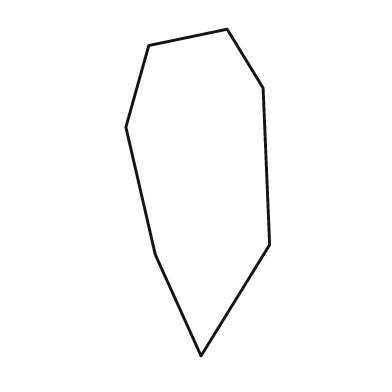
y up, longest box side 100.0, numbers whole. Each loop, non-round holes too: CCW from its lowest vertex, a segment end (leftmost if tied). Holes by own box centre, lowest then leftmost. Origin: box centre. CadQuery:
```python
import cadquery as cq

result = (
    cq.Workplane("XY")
    .moveTo(1.0, -50.0)
    .lineTo(22.0, -16.0)
    .lineTo(20.0, 32.0)
    .lineTo(9.0, 50.0)
    .lineTo(-15.0, 45.0)
    .lineTo(-22.0, 20.0)
    .lineTo(-13.0, -19.0)
    .close()
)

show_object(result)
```